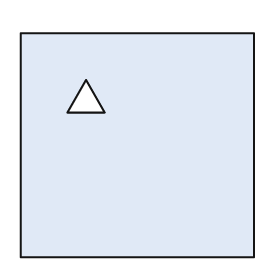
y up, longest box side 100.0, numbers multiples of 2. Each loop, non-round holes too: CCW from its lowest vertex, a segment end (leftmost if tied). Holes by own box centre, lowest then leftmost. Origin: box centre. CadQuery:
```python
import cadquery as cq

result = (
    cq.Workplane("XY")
    .moveTo(-50.0, -48.0)
    .lineTo(50.0, -48.0)
    .lineTo(50.0, 48.0)
    .lineTo(-50.0, 48.0)
    .close()
    .moveTo(-30.0, 14.0)
    .lineTo(-14.0, 14.0)
    .lineTo(-22.0, 28.0)
    .close()
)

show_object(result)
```